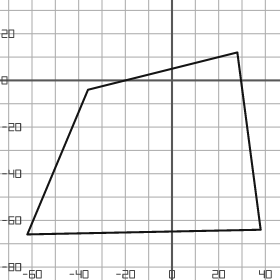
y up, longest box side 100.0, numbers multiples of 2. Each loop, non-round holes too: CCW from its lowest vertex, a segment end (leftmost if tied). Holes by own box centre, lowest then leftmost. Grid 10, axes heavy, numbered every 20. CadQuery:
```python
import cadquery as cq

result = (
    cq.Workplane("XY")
    .moveTo(-62.0, -66.0)
    .lineTo(38.0, -64.0)
    .lineTo(28.0, 12.0)
    .lineTo(-36.0, -4.0)
    .close()
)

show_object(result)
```